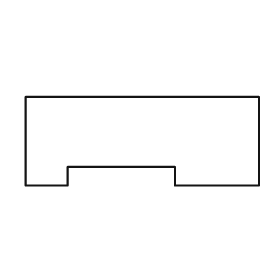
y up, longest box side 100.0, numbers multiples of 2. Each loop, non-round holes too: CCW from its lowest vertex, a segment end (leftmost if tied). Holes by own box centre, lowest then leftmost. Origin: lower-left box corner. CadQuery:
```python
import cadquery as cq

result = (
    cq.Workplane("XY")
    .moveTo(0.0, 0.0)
    .lineTo(18.0, 0.0)
    .lineTo(18.0, 8.0)
    .lineTo(64.0, 8.0)
    .lineTo(64.0, 0.0)
    .lineTo(100.0, 0.0)
    .lineTo(100.0, 38.0)
    .lineTo(0.0, 38.0)
    .close()
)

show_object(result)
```